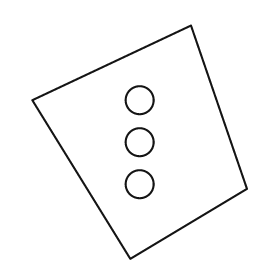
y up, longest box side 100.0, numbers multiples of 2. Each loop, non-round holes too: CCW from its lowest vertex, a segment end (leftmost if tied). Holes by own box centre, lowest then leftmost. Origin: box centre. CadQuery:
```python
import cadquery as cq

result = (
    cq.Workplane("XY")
    .moveTo(-4.0, -50.0)
    .lineTo(46.0, -20.0)
    .lineTo(22.0, 50.0)
    .lineTo(-46.0, 18.0)
    .close()
    .moveTo(0.0, -18.0)
    .circle(6.0)
    .moveTo(0.0, 0.0)
    .circle(6.0)
    .moveTo(0.0, 18.0)
    .circle(6.0)
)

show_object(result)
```